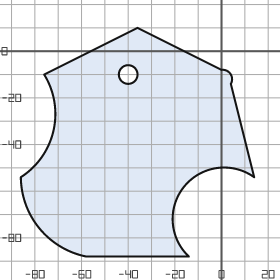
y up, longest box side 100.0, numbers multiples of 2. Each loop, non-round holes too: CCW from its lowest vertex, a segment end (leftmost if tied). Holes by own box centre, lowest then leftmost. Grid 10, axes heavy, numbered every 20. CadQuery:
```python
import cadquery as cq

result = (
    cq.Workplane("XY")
    .moveTo(-58.0, -88.0)
    .lineTo(-14.0, -88.0)
    .threePointArc((-16.0, -58.0), (14.0, -54.0))
    .lineTo(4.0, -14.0)
    .threePointArc((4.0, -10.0), (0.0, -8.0))
    .lineTo(-36.0, 10.0)
    .lineTo(-76.0, -10.0)
    .threePointArc((-72.0, -34.0), (-86.0, -54.0))
    .threePointArc((-78.0, -76.0), (-58.0, -88.0))
    .close()
    .moveTo(-40.0, -10.0)
    .circle(4.0)
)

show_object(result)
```